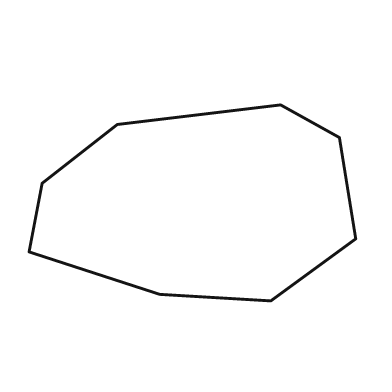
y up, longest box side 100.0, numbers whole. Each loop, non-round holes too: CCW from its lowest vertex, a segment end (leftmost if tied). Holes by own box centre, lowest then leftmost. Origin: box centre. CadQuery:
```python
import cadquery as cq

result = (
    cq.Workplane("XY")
    .moveTo(24.0, -30.0)
    .lineTo(50.0, -11.0)
    .lineTo(45.0, 20.0)
    .lineTo(27.0, 30.0)
    .lineTo(-23.0, 24.0)
    .lineTo(-46.0, 6.0)
    .lineTo(-50.0, -15.0)
    .lineTo(-10.0, -28.0)
    .close()
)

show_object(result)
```